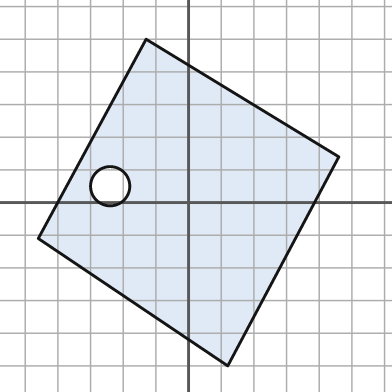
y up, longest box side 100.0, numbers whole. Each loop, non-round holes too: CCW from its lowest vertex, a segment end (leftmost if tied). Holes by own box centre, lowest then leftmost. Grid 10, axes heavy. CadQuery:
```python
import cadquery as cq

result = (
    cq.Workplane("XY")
    .moveTo(12.0, -50.0)
    .lineTo(46.0, 14.0)
    .lineTo(-13.0, 50.0)
    .lineTo(-46.0, -11.0)
    .close()
    .moveTo(-24.0, 5.0)
    .circle(6.0)
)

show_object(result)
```